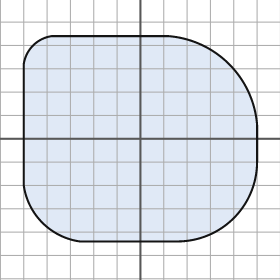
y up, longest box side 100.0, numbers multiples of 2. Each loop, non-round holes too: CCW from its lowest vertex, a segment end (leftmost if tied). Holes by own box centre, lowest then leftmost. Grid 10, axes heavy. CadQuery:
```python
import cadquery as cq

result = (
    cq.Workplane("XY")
    .moveTo(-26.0, -44.0)
    .lineTo(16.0, -44.0)
    .threePointArc((40.0, -34.0), (50.0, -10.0))
    .lineTo(50.0, 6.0)
    .threePointArc((38.0, 32.0), (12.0, 44.0))
    .lineTo(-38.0, 44.0)
    .threePointArc((-46.0, 40.0), (-50.0, 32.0))
    .lineTo(-50.0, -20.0)
    .threePointArc((-42.0, -36.0), (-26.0, -44.0))
    .close()
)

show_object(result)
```